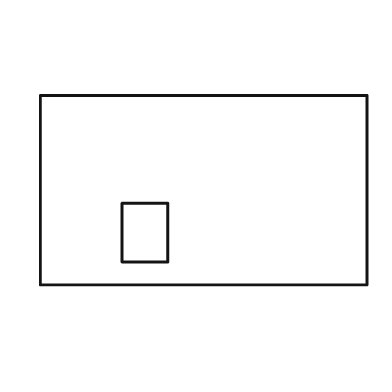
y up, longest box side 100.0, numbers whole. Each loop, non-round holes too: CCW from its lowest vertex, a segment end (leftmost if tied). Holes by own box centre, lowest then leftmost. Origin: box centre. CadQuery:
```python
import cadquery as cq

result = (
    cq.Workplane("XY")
    .moveTo(-50.0, -29.0)
    .lineTo(50.0, -29.0)
    .lineTo(50.0, 29.0)
    .lineTo(-50.0, 29.0)
    .close()
    .moveTo(-25.0, -22.0)
    .lineTo(-11.0, -22.0)
    .lineTo(-11.0, -4.0)
    .lineTo(-25.0, -4.0)
    .close()
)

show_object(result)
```